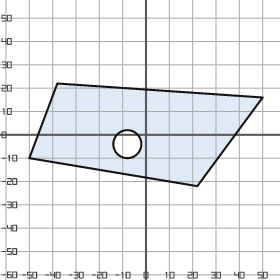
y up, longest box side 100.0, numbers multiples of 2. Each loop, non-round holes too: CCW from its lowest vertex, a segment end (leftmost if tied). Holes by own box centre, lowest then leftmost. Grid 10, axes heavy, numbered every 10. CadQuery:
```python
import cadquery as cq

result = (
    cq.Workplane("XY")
    .moveTo(22.0, -22.0)
    .lineTo(50.0, 16.0)
    .lineTo(-38.0, 22.0)
    .lineTo(-50.0, -10.0)
    .close()
    .moveTo(-8.0, -4.0)
    .circle(6.0)
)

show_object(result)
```